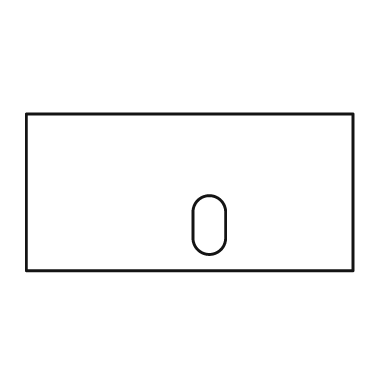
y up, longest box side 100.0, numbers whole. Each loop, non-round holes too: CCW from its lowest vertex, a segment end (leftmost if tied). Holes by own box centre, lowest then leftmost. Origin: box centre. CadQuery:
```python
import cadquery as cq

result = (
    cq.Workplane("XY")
    .moveTo(-50.0, -24.0)
    .lineTo(50.0, -24.0)
    .lineTo(50.0, 24.0)
    .lineTo(-50.0, 24.0)
    .close()
    .moveTo(1.0, -14.0)
    .threePointArc((6.0, -19.0), (11.0, -14.0))
    .lineTo(11.0, -6.0)
    .threePointArc((6.0, -1.0), (1.0, -6.0))
    .close()
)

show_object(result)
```